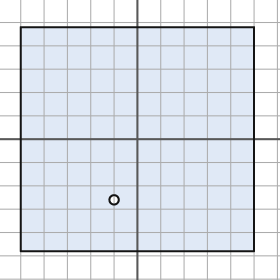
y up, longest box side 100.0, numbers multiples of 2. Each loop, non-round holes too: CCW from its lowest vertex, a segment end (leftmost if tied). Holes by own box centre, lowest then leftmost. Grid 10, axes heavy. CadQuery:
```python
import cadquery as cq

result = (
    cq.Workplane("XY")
    .moveTo(-50.0, -48.0)
    .lineTo(50.0, -48.0)
    .lineTo(50.0, 48.0)
    .lineTo(-50.0, 48.0)
    .close()
    .moveTo(-10.0, -26.0)
    .circle(2.0)
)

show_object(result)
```